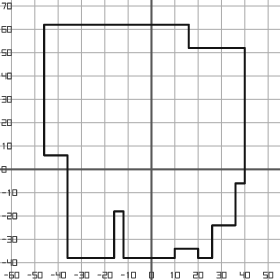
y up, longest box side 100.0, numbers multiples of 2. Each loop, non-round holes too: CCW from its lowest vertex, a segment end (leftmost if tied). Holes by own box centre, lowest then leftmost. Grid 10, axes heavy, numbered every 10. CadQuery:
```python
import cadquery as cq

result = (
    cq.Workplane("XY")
    .moveTo(-36.0, -38.0)
    .lineTo(-16.0, -38.0)
    .lineTo(-16.0, -18.0)
    .lineTo(-12.0, -18.0)
    .lineTo(-12.0, -38.0)
    .lineTo(10.0, -38.0)
    .lineTo(10.0, -34.0)
    .lineTo(20.0, -34.0)
    .lineTo(20.0, -38.0)
    .lineTo(26.0, -38.0)
    .lineTo(26.0, -24.0)
    .lineTo(36.0, -24.0)
    .lineTo(36.0, -6.0)
    .lineTo(40.0, -6.0)
    .lineTo(40.0, 52.0)
    .lineTo(16.0, 52.0)
    .lineTo(16.0, 62.0)
    .lineTo(-46.0, 62.0)
    .lineTo(-46.0, 6.0)
    .lineTo(-36.0, 6.0)
    .close()
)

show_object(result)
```